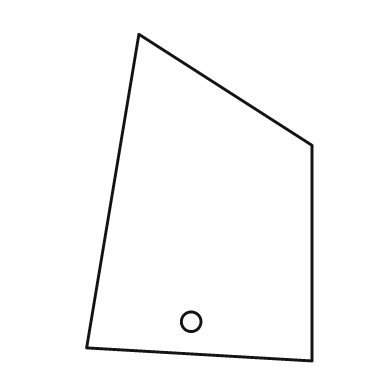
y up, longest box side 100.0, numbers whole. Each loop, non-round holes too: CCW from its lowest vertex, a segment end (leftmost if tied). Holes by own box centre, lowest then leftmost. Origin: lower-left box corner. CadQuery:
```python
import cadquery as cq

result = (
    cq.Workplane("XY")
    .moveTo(69.0, 0.0)
    .lineTo(69.0, 66.0)
    .lineTo(16.0, 100.0)
    .lineTo(0.0, 4.0)
    .close()
    .moveTo(32.0, 12.0)
    .circle(3.0)
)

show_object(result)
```